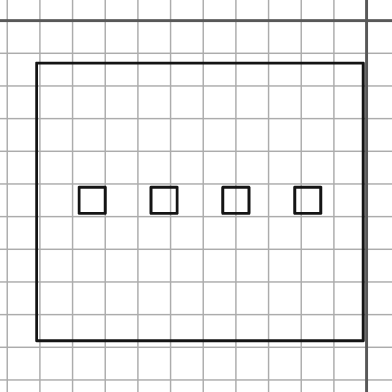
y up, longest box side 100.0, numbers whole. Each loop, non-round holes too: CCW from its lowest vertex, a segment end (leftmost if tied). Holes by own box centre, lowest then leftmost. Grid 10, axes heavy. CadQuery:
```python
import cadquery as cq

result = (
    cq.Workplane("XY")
    .moveTo(-101.0, -98.0)
    .lineTo(-1.0, -98.0)
    .lineTo(-1.0, -13.0)
    .lineTo(-101.0, -13.0)
    .close()
    .moveTo(-88.0, -59.0)
    .lineTo(-80.0, -59.0)
    .lineTo(-80.0, -51.0)
    .lineTo(-88.0, -51.0)
    .close()
    .moveTo(-66.0, -59.0)
    .lineTo(-58.0, -59.0)
    .lineTo(-58.0, -51.0)
    .lineTo(-66.0, -51.0)
    .close()
    .moveTo(-44.0, -59.0)
    .lineTo(-36.0, -59.0)
    .lineTo(-36.0, -51.0)
    .lineTo(-44.0, -51.0)
    .close()
    .moveTo(-22.0, -59.0)
    .lineTo(-14.0, -59.0)
    .lineTo(-14.0, -51.0)
    .lineTo(-22.0, -51.0)
    .close()
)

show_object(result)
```